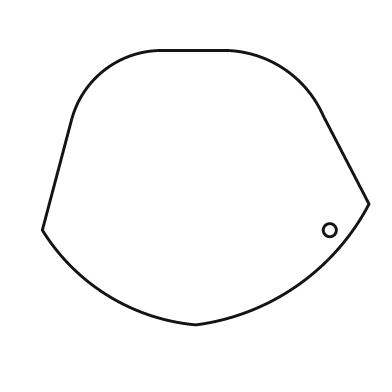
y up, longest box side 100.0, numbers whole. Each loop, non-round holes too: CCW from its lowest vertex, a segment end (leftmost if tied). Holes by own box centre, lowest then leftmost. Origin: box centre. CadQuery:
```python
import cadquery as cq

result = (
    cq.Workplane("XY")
    .moveTo(-3.0, -42.0)
    .threePointArc((28.0, -30.0), (50.0, -5.0))
    .lineTo(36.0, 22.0)
    .threePointArc((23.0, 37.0), (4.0, 42.0))
    .lineTo(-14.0, 42.0)
    .threePointArc((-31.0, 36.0), (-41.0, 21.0))
    .lineTo(-50.0, -13.0)
    .threePointArc((-30.0, -33.0), (-3.0, -42.0))
    .close()
    .moveTo(38.0, -13.0)
    .circle(2.0)
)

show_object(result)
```